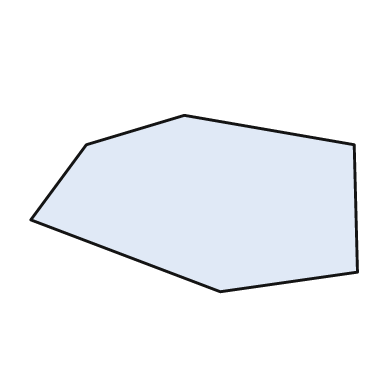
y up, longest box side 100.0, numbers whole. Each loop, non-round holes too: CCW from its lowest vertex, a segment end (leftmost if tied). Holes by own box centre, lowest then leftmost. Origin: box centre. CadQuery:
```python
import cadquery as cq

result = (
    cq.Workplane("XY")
    .moveTo(8.0, -27.0)
    .lineTo(50.0, -21.0)
    .lineTo(49.0, 18.0)
    .lineTo(-3.0, 27.0)
    .lineTo(-33.0, 18.0)
    .lineTo(-50.0, -5.0)
    .close()
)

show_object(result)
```